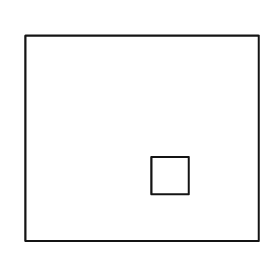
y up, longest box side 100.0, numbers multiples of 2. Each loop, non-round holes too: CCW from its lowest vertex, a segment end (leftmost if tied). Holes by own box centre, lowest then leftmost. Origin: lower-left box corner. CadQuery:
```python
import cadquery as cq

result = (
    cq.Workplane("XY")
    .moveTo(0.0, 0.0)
    .lineTo(100.0, 0.0)
    .lineTo(100.0, 88.0)
    .lineTo(0.0, 88.0)
    .close()
    .moveTo(54.0, 20.0)
    .lineTo(70.0, 20.0)
    .lineTo(70.0, 36.0)
    .lineTo(54.0, 36.0)
    .close()
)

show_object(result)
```